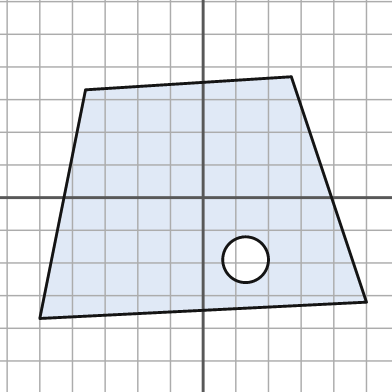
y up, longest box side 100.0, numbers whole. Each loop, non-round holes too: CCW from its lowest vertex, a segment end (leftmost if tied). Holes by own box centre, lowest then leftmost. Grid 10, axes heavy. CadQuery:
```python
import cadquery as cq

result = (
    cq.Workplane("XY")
    .moveTo(-50.0, -37.0)
    .lineTo(50.0, -32.0)
    .lineTo(27.0, 37.0)
    .lineTo(-36.0, 33.0)
    .close()
    .moveTo(13.0, -19.0)
    .circle(7.0)
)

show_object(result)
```